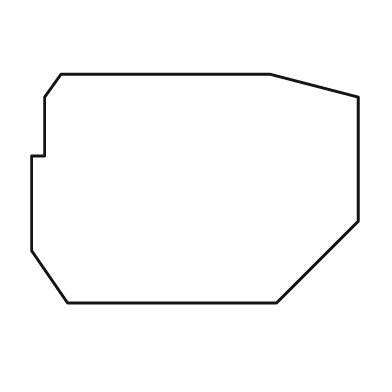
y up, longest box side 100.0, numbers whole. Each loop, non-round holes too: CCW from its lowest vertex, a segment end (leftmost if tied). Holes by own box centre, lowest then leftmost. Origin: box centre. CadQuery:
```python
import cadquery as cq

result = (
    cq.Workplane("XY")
    .moveTo(-39.0, -35.0)
    .lineTo(25.0, -35.0)
    .lineTo(50.0, -10.0)
    .lineTo(50.0, 28.0)
    .lineTo(23.0, 35.0)
    .lineTo(-41.0, 35.0)
    .lineTo(-46.0, 28.0)
    .lineTo(-46.0, 10.0)
    .lineTo(-50.0, 10.0)
    .lineTo(-50.0, -19.0)
    .close()
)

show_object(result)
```